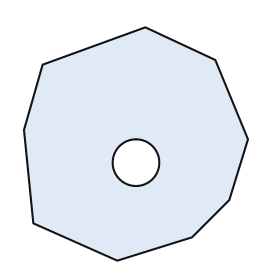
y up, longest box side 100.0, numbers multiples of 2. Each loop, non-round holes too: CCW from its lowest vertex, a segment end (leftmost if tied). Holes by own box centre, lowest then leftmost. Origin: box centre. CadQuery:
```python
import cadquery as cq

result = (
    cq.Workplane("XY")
    .moveTo(-8.0, -50.0)
    .lineTo(24.0, -40.0)
    .lineTo(40.0, -24.0)
    .lineTo(48.0, 2.0)
    .lineTo(34.0, 36.0)
    .lineTo(4.0, 50.0)
    .lineTo(-40.0, 34.0)
    .lineTo(-48.0, 6.0)
    .lineTo(-44.0, -34.0)
    .close()
    .moveTo(0.0, -8.0)
    .circle(10.0)
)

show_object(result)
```